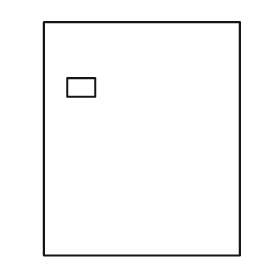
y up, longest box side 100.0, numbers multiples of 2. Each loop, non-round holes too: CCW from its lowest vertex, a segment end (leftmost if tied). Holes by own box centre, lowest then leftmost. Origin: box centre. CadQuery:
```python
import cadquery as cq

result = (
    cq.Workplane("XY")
    .moveTo(-42.0, -50.0)
    .lineTo(42.0, -50.0)
    .lineTo(42.0, 50.0)
    .lineTo(-42.0, 50.0)
    .close()
    .moveTo(-32.0, 18.0)
    .lineTo(-20.0, 18.0)
    .lineTo(-20.0, 26.0)
    .lineTo(-32.0, 26.0)
    .close()
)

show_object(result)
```